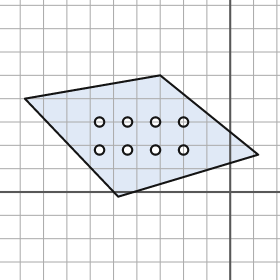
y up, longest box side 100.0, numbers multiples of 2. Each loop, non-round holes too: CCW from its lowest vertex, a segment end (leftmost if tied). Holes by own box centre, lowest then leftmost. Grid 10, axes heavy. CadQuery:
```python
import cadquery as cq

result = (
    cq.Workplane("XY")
    .moveTo(-48.0, -2.0)
    .lineTo(12.0, 16.0)
    .lineTo(-30.0, 50.0)
    .lineTo(-88.0, 40.0)
    .close()
    .moveTo(-56.0, 18.0)
    .circle(2.0)
    .moveTo(-44.0, 18.0)
    .circle(2.0)
    .moveTo(-32.0, 18.0)
    .circle(2.0)
    .moveTo(-20.0, 18.0)
    .circle(2.0)
    .moveTo(-56.0, 30.0)
    .circle(2.0)
    .moveTo(-44.0, 30.0)
    .circle(2.0)
    .moveTo(-32.0, 30.0)
    .circle(2.0)
    .moveTo(-20.0, 30.0)
    .circle(2.0)
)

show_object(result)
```